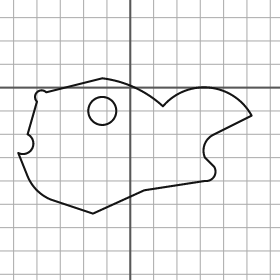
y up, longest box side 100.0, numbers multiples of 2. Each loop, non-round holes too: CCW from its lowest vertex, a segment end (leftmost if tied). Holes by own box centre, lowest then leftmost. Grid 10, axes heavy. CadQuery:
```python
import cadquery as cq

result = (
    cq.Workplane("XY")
    .moveTo(-16.0, -54.0)
    .lineTo(6.0, -44.0)
    .lineTo(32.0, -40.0)
    .threePointArc((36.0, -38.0), (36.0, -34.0))
    .lineTo(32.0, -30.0)
    .threePointArc((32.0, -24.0), (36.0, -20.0))
    .lineTo(52.0, -12.0)
    .threePointArc((34.0, 0.0), (14.0, -8.0))
    .threePointArc((2.0, 0.0), (-12.0, 4.0))
    .lineTo(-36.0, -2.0)
    .threePointArc((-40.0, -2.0), (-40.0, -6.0))
    .lineTo(-44.0, -20.0)
    .threePointArc((-42.0, -26.0), (-48.0, -28.0))
    .lineTo(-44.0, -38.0)
    .threePointArc((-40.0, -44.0), (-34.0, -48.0))
    .close()
    .moveTo(-12.0, -10.0)
    .circle(6.0)
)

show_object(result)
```